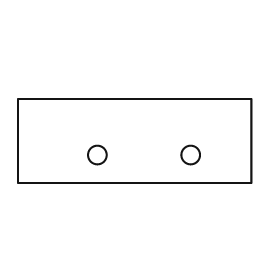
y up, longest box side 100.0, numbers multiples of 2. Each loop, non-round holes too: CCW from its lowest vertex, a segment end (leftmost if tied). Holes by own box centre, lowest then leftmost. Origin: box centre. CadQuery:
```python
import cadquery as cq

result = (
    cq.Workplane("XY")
    .moveTo(-50.0, -18.0)
    .lineTo(50.0, -18.0)
    .lineTo(50.0, 18.0)
    .lineTo(-50.0, 18.0)
    .close()
    .moveTo(-16.0, -6.0)
    .circle(4.0)
    .moveTo(24.0, -6.0)
    .circle(4.0)
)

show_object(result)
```